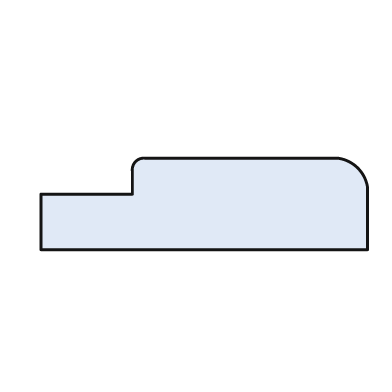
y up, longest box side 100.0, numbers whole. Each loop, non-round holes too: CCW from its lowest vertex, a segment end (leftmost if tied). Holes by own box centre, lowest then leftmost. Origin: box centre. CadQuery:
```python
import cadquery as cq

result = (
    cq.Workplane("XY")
    .moveTo(-50.0, -14.0)
    .lineTo(50.0, -14.0)
    .lineTo(50.0, 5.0)
    .threePointArc((47.0, 11.0), (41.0, 14.0))
    .lineTo(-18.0, 14.0)
    .threePointArc((-21.0, 13.0), (-22.0, 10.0))
    .lineTo(-22.0, 3.0)
    .lineTo(-50.0, 3.0)
    .close()
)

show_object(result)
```